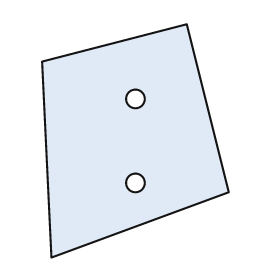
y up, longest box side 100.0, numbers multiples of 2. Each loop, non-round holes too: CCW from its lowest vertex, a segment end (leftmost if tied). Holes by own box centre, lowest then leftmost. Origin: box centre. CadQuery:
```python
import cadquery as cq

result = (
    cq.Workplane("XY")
    .moveTo(-36.0, -50.0)
    .lineTo(40.0, -22.0)
    .lineTo(22.0, 50.0)
    .lineTo(-40.0, 34.0)
    .close()
    .moveTo(0.0, -18.0)
    .circle(4.0)
    .moveTo(0.0, 18.0)
    .circle(4.0)
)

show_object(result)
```